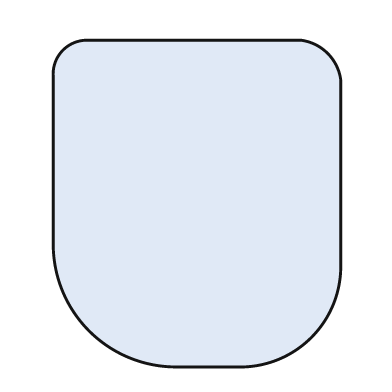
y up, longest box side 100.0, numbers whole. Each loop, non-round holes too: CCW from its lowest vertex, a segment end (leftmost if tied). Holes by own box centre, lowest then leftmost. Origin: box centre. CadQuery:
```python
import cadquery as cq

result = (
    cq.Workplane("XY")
    .moveTo(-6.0, -50.0)
    .lineTo(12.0, -50.0)
    .threePointArc((35.0, -41.0), (44.0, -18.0))
    .lineTo(44.0, 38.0)
    .threePointArc((40.0, 46.0), (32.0, 50.0))
    .lineTo(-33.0, 50.0)
    .threePointArc((-41.0, 47.0), (-44.0, 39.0))
    .lineTo(-44.0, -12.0)
    .threePointArc((-33.0, -39.0), (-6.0, -50.0))
    .close()
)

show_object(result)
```